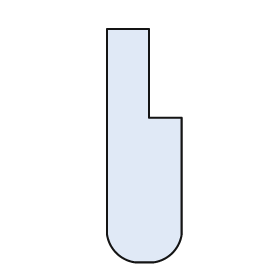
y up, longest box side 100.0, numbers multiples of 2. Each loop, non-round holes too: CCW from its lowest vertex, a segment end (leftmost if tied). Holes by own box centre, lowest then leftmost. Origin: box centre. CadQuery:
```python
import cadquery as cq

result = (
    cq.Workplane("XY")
    .moveTo(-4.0, -50.0)
    .lineTo(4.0, -50.0)
    .threePointArc((12.0, -46.0), (16.0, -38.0))
    .lineTo(16.0, 12.0)
    .lineTo(2.0, 12.0)
    .lineTo(2.0, 50.0)
    .lineTo(-16.0, 50.0)
    .lineTo(-16.0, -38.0)
    .threePointArc((-12.0, -46.0), (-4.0, -50.0))
    .close()
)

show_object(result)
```